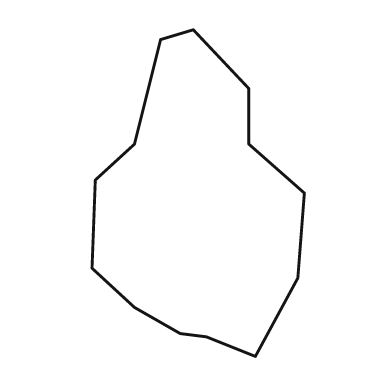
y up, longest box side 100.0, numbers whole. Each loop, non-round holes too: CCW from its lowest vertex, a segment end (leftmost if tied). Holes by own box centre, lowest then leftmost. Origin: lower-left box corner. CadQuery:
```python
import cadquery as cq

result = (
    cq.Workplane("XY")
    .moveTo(50.0, 0.0)
    .lineTo(63.0, 24.0)
    .lineTo(65.0, 50.0)
    .lineTo(48.0, 65.0)
    .lineTo(48.0, 82.0)
    .lineTo(31.0, 100.0)
    .lineTo(21.0, 97.0)
    .lineTo(13.0, 65.0)
    .lineTo(1.0, 54.0)
    .lineTo(0.0, 27.0)
    .lineTo(13.0, 15.0)
    .lineTo(27.0, 7.0)
    .lineTo(35.0, 6.0)
    .close()
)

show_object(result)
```